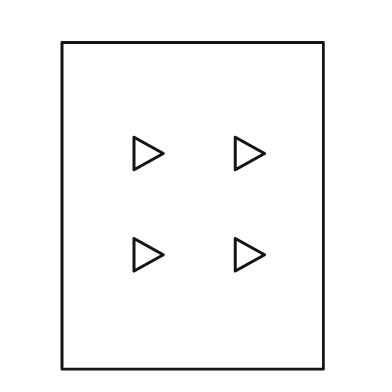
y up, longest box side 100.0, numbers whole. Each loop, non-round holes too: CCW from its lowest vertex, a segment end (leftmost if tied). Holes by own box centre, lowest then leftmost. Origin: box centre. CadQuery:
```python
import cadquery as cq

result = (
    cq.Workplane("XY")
    .moveTo(-40.0, -50.0)
    .lineTo(40.0, -50.0)
    .lineTo(40.0, 50.0)
    .lineTo(-40.0, 50.0)
    .close()
    .moveTo(-18.0, -20.0)
    .lineTo(-9.0, -15.0)
    .lineTo(-18.0, -10.0)
    .close()
    .moveTo(13.0, -20.0)
    .lineTo(22.0, -15.0)
    .lineTo(13.0, -10.0)
    .close()
    .moveTo(-18.0, 11.0)
    .lineTo(-9.0, 16.0)
    .lineTo(-18.0, 21.0)
    .close()
    .moveTo(13.0, 11.0)
    .lineTo(22.0, 16.0)
    .lineTo(13.0, 21.0)
    .close()
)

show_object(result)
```